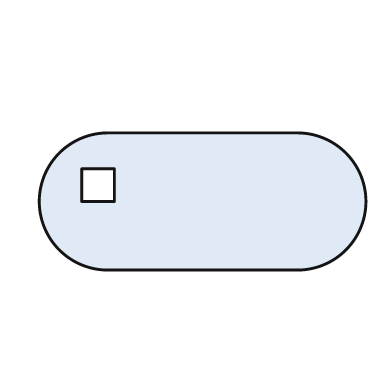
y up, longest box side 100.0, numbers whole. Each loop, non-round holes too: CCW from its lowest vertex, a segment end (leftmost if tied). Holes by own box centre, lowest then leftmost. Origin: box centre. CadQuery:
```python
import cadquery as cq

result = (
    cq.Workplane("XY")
    .moveTo(-29.0, -21.0)
    .lineTo(29.0, -21.0)
    .threePointArc((50.0, 0.0), (29.0, 21.0))
    .lineTo(-29.0, 21.0)
    .threePointArc((-50.0, 0.0), (-29.0, -21.0))
    .close()
    .moveTo(-37.0, 0.0)
    .lineTo(-27.0, 0.0)
    .lineTo(-27.0, 10.0)
    .lineTo(-37.0, 10.0)
    .close()
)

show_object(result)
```